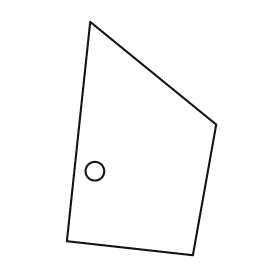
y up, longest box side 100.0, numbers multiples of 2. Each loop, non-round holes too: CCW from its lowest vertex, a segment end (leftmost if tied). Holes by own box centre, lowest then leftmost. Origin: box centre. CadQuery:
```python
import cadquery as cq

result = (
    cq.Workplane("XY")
    .moveTo(22.0, -50.0)
    .lineTo(32.0, 6.0)
    .lineTo(-22.0, 50.0)
    .lineTo(-32.0, -44.0)
    .close()
    .moveTo(-20.0, -14.0)
    .circle(4.0)
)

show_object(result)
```